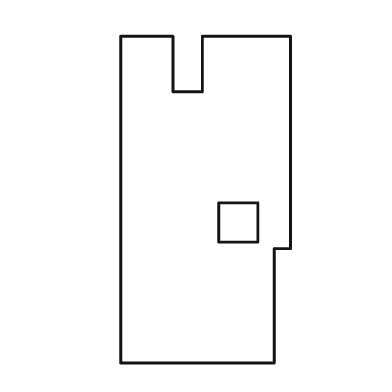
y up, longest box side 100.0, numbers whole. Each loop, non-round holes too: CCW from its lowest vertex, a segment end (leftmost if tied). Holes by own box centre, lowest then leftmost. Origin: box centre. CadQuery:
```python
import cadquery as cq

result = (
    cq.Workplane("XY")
    .moveTo(-26.0, -50.0)
    .lineTo(21.0, -50.0)
    .lineTo(21.0, -15.0)
    .lineTo(26.0, -15.0)
    .lineTo(26.0, 50.0)
    .lineTo(-1.0, 50.0)
    .lineTo(-1.0, 33.0)
    .lineTo(-10.0, 33.0)
    .lineTo(-10.0, 50.0)
    .lineTo(-26.0, 50.0)
    .close()
    .moveTo(4.0, -13.0)
    .lineTo(16.0, -13.0)
    .lineTo(16.0, -1.0)
    .lineTo(4.0, -1.0)
    .close()
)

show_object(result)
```